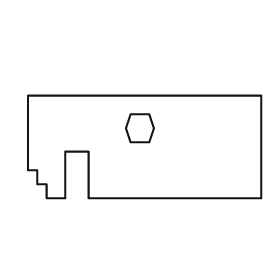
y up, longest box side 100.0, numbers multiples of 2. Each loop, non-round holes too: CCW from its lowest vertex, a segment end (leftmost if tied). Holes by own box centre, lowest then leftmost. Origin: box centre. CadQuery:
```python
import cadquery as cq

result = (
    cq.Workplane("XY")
    .moveTo(-42.0, -22.0)
    .lineTo(-34.0, -22.0)
    .lineTo(-34.0, -2.0)
    .lineTo(-24.0, -2.0)
    .lineTo(-24.0, -22.0)
    .lineTo(50.0, -22.0)
    .lineTo(50.0, 22.0)
    .lineTo(-50.0, 22.0)
    .lineTo(-50.0, -10.0)
    .lineTo(-46.0, -10.0)
    .lineTo(-46.0, -16.0)
    .lineTo(-42.0, -16.0)
    .close()
    .moveTo(-6.0, 2.0)
    .lineTo(2.0, 2.0)
    .lineTo(4.0, 8.0)
    .lineTo(2.0, 14.0)
    .lineTo(-6.0, 14.0)
    .lineTo(-8.0, 8.0)
    .close()
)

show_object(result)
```